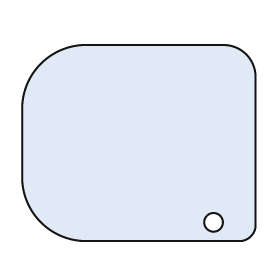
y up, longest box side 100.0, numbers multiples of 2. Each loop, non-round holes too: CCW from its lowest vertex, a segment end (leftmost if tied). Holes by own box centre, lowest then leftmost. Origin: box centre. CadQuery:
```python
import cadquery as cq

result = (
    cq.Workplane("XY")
    .moveTo(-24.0, -42.0)
    .lineTo(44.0, -42.0)
    .threePointArc((48.0, -40.0), (50.0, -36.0))
    .lineTo(50.0, 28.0)
    .threePointArc((46.0, 38.0), (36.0, 42.0))
    .lineTo(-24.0, 42.0)
    .threePointArc((-42.0, 34.0), (-50.0, 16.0))
    .lineTo(-50.0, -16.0)
    .threePointArc((-42.0, -34.0), (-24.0, -42.0))
    .close()
    .moveTo(32.0, -34.0)
    .circle(4.0)
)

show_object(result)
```